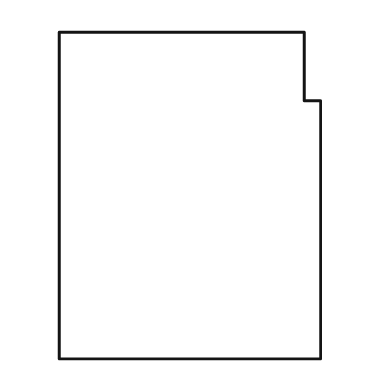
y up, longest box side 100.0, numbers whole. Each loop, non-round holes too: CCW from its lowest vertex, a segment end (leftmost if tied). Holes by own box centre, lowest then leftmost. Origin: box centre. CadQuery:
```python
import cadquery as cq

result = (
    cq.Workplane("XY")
    .moveTo(-40.0, -50.0)
    .lineTo(40.0, -50.0)
    .lineTo(40.0, 29.0)
    .lineTo(35.0, 29.0)
    .lineTo(35.0, 50.0)
    .lineTo(-40.0, 50.0)
    .close()
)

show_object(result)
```